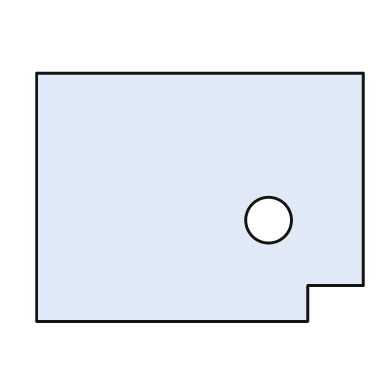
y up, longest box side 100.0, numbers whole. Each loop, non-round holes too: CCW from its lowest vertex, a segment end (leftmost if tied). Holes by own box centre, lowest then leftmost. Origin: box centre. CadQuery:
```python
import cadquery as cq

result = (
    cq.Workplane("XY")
    .moveTo(-50.0, -38.0)
    .lineTo(33.0, -38.0)
    .lineTo(33.0, -27.0)
    .lineTo(50.0, -27.0)
    .lineTo(50.0, 38.0)
    .lineTo(-50.0, 38.0)
    .close()
    .moveTo(21.0, -7.0)
    .circle(7.0)
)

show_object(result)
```